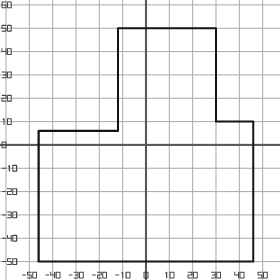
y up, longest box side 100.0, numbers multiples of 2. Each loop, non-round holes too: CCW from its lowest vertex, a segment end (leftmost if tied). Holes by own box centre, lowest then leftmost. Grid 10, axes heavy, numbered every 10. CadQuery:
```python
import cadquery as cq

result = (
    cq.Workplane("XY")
    .moveTo(-46.0, -50.0)
    .lineTo(46.0, -50.0)
    .lineTo(46.0, 10.0)
    .lineTo(30.0, 10.0)
    .lineTo(30.0, 50.0)
    .lineTo(-12.0, 50.0)
    .lineTo(-12.0, 6.0)
    .lineTo(-46.0, 6.0)
    .close()
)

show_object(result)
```